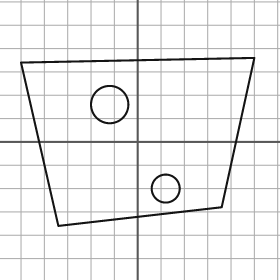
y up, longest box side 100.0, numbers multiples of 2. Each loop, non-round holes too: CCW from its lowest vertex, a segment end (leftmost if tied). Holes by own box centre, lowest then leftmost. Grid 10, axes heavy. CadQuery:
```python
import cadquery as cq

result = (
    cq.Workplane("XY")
    .moveTo(-34.0, -36.0)
    .lineTo(36.0, -28.0)
    .lineTo(50.0, 36.0)
    .lineTo(-50.0, 34.0)
    .close()
    .moveTo(12.0, -20.0)
    .circle(6.0)
    .moveTo(-12.0, 16.0)
    .circle(8.0)
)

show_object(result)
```